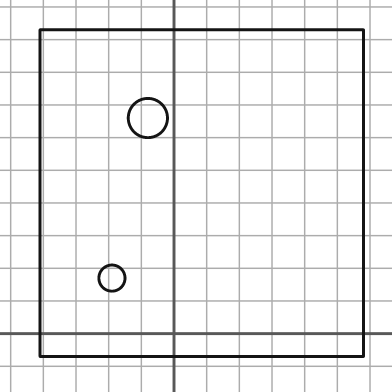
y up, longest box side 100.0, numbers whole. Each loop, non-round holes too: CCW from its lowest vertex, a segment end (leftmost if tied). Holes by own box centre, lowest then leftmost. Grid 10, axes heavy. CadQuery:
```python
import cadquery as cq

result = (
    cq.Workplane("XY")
    .moveTo(-41.0, -7.0)
    .lineTo(58.0, -7.0)
    .lineTo(58.0, 93.0)
    .lineTo(-41.0, 93.0)
    .close()
    .moveTo(-19.0, 17.0)
    .circle(4.0)
    .moveTo(-8.0, 66.0)
    .circle(6.0)
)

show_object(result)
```